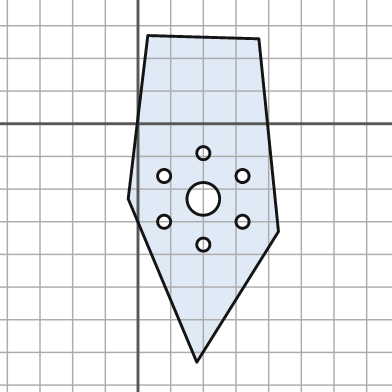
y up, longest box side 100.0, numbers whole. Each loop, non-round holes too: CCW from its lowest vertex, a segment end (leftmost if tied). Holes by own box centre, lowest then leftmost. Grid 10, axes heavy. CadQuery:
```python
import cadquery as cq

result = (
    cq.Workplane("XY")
    .moveTo(18.0, -73.0)
    .lineTo(43.0, -33.0)
    .lineTo(37.0, 26.0)
    .lineTo(3.0, 27.0)
    .lineTo(-3.0, -23.0)
    .close()
    .moveTo(20.0, -37.0)
    .circle(2.0)
    .moveTo(8.0, -30.0)
    .circle(2.0)
    .moveTo(32.0, -30.0)
    .circle(2.0)
    .moveTo(20.0, -23.0)
    .circle(5.0)
    .moveTo(8.0, -16.0)
    .circle(2.0)
    .moveTo(32.0, -16.0)
    .circle(2.0)
    .moveTo(20.0, -9.0)
    .circle(2.0)
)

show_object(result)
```